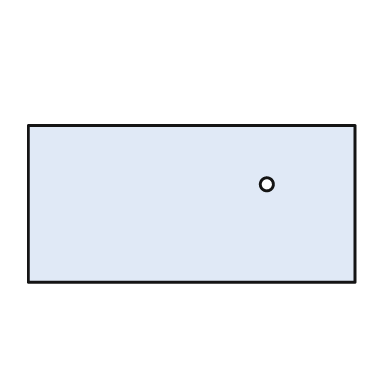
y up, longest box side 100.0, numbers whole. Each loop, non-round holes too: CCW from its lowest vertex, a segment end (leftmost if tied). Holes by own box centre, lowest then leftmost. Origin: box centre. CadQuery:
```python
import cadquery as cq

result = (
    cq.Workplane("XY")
    .moveTo(-50.0, -24.0)
    .lineTo(50.0, -24.0)
    .lineTo(50.0, 24.0)
    .lineTo(-50.0, 24.0)
    .close()
    .moveTo(23.0, 6.0)
    .circle(2.0)
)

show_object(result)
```